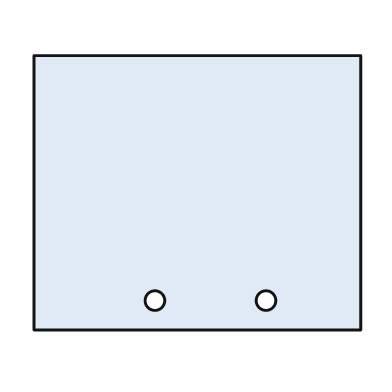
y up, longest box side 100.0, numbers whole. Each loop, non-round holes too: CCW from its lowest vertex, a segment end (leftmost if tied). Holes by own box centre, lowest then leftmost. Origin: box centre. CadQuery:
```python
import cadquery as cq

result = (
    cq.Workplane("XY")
    .moveTo(-50.0, -42.0)
    .lineTo(50.0, -42.0)
    .lineTo(50.0, 42.0)
    .lineTo(-50.0, 42.0)
    .close()
    .moveTo(-13.0, -33.0)
    .circle(3.0)
    .moveTo(21.0, -33.0)
    .circle(3.0)
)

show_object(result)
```